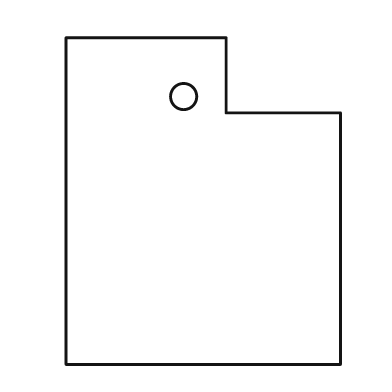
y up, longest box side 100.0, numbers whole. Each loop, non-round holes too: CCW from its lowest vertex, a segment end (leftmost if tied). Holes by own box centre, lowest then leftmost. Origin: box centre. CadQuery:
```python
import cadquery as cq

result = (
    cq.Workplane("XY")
    .moveTo(-42.0, -50.0)
    .lineTo(42.0, -50.0)
    .lineTo(42.0, 27.0)
    .lineTo(7.0, 27.0)
    .lineTo(7.0, 50.0)
    .lineTo(-42.0, 50.0)
    .close()
    .moveTo(-6.0, 32.0)
    .circle(4.0)
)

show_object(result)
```